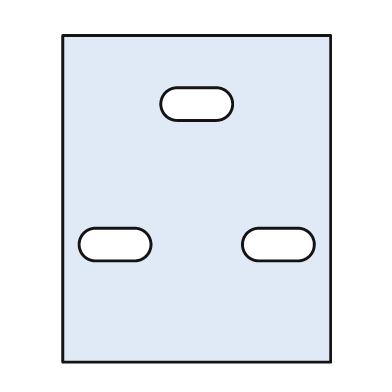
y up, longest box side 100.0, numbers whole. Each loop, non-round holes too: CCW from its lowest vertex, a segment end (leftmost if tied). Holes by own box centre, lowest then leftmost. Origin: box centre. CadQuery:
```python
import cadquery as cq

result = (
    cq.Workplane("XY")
    .moveTo(-41.0, -50.0)
    .lineTo(41.0, -50.0)
    .lineTo(41.0, 50.0)
    .lineTo(-41.0, 50.0)
    .close()
    .moveTo(-31.0, -19.0)
    .lineTo(-19.0, -19.0)
    .threePointArc((-14.0, -14.0), (-19.0, -9.0))
    .lineTo(-31.0, -9.0)
    .threePointArc((-36.0, -14.0), (-31.0, -19.0))
    .close()
    .moveTo(19.0, -19.0)
    .lineTo(31.0, -19.0)
    .threePointArc((36.0, -14.0), (31.0, -9.0))
    .lineTo(19.0, -9.0)
    .threePointArc((14.0, -14.0), (19.0, -19.0))
    .close()
    .moveTo(-6.0, 24.0)
    .lineTo(6.0, 24.0)
    .threePointArc((11.0, 29.0), (6.0, 34.0))
    .lineTo(-6.0, 34.0)
    .threePointArc((-11.0, 29.0), (-6.0, 24.0))
    .close()
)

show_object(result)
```